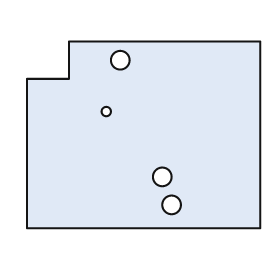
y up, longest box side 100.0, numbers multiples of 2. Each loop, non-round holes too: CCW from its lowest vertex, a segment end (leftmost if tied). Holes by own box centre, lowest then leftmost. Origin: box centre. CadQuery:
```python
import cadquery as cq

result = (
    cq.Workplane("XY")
    .moveTo(-50.0, -40.0)
    .lineTo(50.0, -40.0)
    .lineTo(50.0, 40.0)
    .lineTo(-32.0, 40.0)
    .lineTo(-32.0, 24.0)
    .lineTo(-50.0, 24.0)
    .close()
    .moveTo(12.0, -30.0)
    .circle(4.0)
    .moveTo(8.0, -18.0)
    .circle(4.0)
    .moveTo(-16.0, 10.0)
    .circle(2.0)
    .moveTo(-10.0, 32.0)
    .circle(4.0)
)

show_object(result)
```